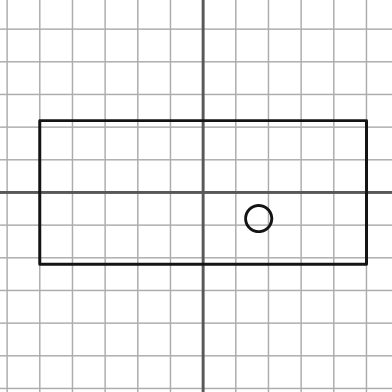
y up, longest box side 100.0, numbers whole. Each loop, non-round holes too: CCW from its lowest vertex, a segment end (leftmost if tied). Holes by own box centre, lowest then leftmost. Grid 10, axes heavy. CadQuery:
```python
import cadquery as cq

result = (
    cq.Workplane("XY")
    .moveTo(-50.0, -22.0)
    .lineTo(50.0, -22.0)
    .lineTo(50.0, 22.0)
    .lineTo(-50.0, 22.0)
    .close()
    .moveTo(17.0, -8.0)
    .circle(4.0)
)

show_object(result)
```